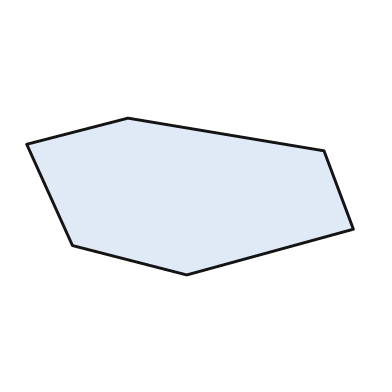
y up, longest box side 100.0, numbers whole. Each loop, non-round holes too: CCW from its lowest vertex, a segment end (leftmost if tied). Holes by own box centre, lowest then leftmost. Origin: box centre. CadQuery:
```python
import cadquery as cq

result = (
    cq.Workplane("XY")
    .moveTo(-1.0, -24.0)
    .lineTo(50.0, -10.0)
    .lineTo(41.0, 14.0)
    .lineTo(-19.0, 24.0)
    .lineTo(-50.0, 16.0)
    .lineTo(-36.0, -15.0)
    .close()
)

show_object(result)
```